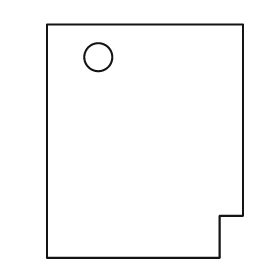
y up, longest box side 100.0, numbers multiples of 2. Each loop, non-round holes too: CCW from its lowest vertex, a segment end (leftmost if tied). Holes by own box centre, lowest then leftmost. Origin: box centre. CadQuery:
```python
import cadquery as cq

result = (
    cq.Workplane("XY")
    .moveTo(-42.0, -50.0)
    .lineTo(32.0, -50.0)
    .lineTo(32.0, -32.0)
    .lineTo(42.0, -32.0)
    .lineTo(42.0, 50.0)
    .lineTo(-42.0, 50.0)
    .close()
    .moveTo(-20.0, 36.0)
    .circle(6.0)
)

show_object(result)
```